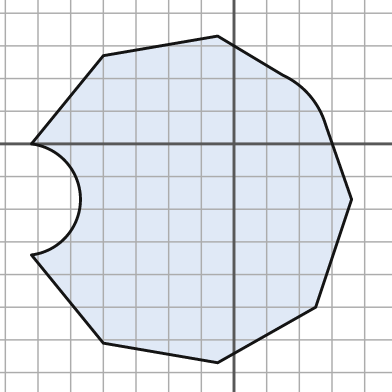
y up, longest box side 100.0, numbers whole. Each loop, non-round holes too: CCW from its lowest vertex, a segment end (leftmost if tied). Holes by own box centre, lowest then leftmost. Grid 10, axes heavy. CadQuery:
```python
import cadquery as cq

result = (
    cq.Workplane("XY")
    .moveTo(-5.0, -67.0)
    .lineTo(25.0, -50.0)
    .lineTo(36.0, -17.0)
    .lineTo(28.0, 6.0)
    .threePointArc((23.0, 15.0), (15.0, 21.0))
    .lineTo(-5.0, 33.0)
    .lineTo(-40.0, 27.0)
    .lineTo(-62.0, 0.0)
    .threePointArc((-47.0, -17.0), (-62.0, -34.0))
    .lineTo(-40.0, -61.0)
    .close()
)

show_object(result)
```